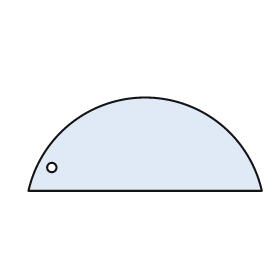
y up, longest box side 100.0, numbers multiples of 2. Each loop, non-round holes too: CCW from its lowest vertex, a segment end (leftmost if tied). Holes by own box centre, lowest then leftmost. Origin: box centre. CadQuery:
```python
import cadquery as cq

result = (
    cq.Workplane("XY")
    .moveTo(-50.0, -20.0)
    .lineTo(50.0, -20.0)
    .threePointArc((0.0, 20.0), (-50.0, -20.0))
    .close()
    .moveTo(-40.0, -10.0)
    .circle(2.0)
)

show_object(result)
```